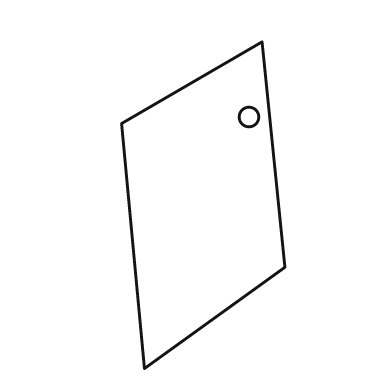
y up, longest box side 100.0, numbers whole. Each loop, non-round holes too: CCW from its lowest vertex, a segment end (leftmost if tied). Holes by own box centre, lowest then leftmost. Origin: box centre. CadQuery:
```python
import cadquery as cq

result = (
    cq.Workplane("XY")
    .moveTo(-18.0, -50.0)
    .lineTo(25.0, -19.0)
    .lineTo(18.0, 50.0)
    .lineTo(-25.0, 25.0)
    .close()
    .moveTo(14.0, 27.0)
    .circle(3.0)
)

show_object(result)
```